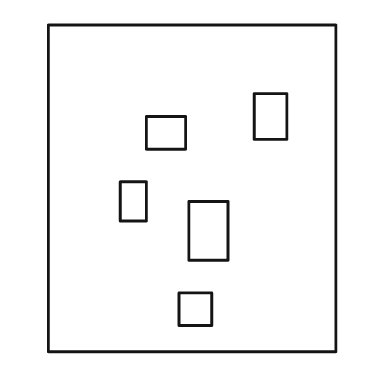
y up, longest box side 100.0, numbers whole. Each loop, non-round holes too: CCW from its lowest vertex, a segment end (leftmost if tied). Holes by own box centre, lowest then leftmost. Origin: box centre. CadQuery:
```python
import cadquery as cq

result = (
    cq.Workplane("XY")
    .moveTo(-44.0, -50.0)
    .lineTo(44.0, -50.0)
    .lineTo(44.0, 50.0)
    .lineTo(-44.0, 50.0)
    .close()
    .moveTo(-4.0, -42.0)
    .lineTo(6.0, -42.0)
    .lineTo(6.0, -32.0)
    .lineTo(-4.0, -32.0)
    .close()
    .moveTo(-1.0, -22.0)
    .lineTo(11.0, -22.0)
    .lineTo(11.0, -4.0)
    .lineTo(-1.0, -4.0)
    .close()
    .moveTo(-22.0, -10.0)
    .lineTo(-14.0, -10.0)
    .lineTo(-14.0, 2.0)
    .lineTo(-22.0, 2.0)
    .close()
    .moveTo(-14.0, 12.0)
    .lineTo(-2.0, 12.0)
    .lineTo(-2.0, 22.0)
    .lineTo(-14.0, 22.0)
    .close()
    .moveTo(19.0, 15.0)
    .lineTo(29.0, 15.0)
    .lineTo(29.0, 29.0)
    .lineTo(19.0, 29.0)
    .close()
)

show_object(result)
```